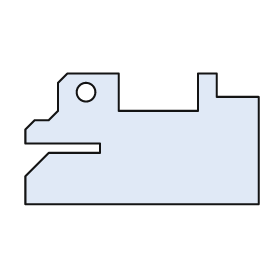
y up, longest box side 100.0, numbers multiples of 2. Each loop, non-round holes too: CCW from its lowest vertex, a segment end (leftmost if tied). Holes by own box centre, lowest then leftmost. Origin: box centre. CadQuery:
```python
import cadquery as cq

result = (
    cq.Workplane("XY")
    .moveTo(-50.0, -28.0)
    .lineTo(50.0, -28.0)
    .lineTo(50.0, 18.0)
    .lineTo(32.0, 18.0)
    .lineTo(32.0, 28.0)
    .lineTo(24.0, 28.0)
    .lineTo(24.0, 12.0)
    .lineTo(-10.0, 12.0)
    .lineTo(-10.0, 28.0)
    .lineTo(-32.0, 28.0)
    .lineTo(-36.0, 24.0)
    .lineTo(-36.0, 12.0)
    .lineTo(-40.0, 8.0)
    .lineTo(-46.0, 8.0)
    .lineTo(-50.0, 4.0)
    .lineTo(-50.0, -2.0)
    .lineTo(-18.0, -2.0)
    .lineTo(-18.0, -6.0)
    .lineTo(-40.0, -6.0)
    .lineTo(-50.0, -16.0)
    .close()
    .moveTo(-24.0, 20.0)
    .circle(4.0)
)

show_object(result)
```